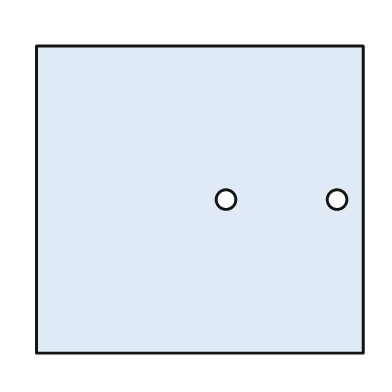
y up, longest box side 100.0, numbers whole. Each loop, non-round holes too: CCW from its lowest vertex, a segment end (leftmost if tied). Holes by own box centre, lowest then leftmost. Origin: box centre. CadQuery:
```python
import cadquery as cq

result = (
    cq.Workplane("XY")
    .moveTo(-50.0, -47.0)
    .lineTo(50.0, -47.0)
    .lineTo(50.0, 47.0)
    .lineTo(-50.0, 47.0)
    .close()
    .moveTo(8.0, 0.0)
    .circle(3.0)
    .moveTo(42.0, 0.0)
    .circle(3.0)
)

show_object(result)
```